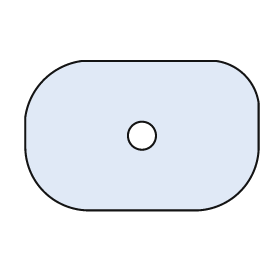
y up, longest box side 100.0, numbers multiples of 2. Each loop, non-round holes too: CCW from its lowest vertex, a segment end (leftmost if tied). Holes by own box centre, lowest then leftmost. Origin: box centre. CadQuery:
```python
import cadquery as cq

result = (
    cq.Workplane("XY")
    .moveTo(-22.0, -32.0)
    .lineTo(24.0, -32.0)
    .threePointArc((42.0, -24.0), (50.0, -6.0))
    .lineTo(50.0, 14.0)
    .threePointArc((44.0, 26.0), (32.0, 32.0))
    .lineTo(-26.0, 32.0)
    .threePointArc((-42.0, 24.0), (-50.0, 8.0))
    .lineTo(-50.0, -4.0)
    .threePointArc((-42.0, -24.0), (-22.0, -32.0))
    .close()
    .moveTo(0.0, 0.0)
    .circle(6.0)
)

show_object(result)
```